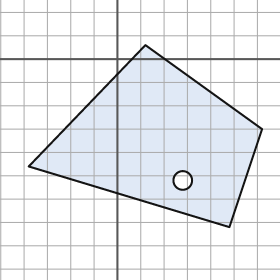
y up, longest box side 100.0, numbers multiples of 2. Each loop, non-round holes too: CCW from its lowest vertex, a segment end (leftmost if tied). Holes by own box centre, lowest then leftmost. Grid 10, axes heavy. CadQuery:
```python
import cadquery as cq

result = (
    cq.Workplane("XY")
    .moveTo(48.0, -72.0)
    .lineTo(62.0, -30.0)
    .lineTo(12.0, 6.0)
    .lineTo(-38.0, -46.0)
    .close()
    .moveTo(28.0, -52.0)
    .circle(4.0)
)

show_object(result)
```